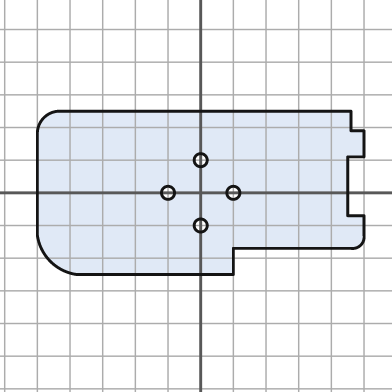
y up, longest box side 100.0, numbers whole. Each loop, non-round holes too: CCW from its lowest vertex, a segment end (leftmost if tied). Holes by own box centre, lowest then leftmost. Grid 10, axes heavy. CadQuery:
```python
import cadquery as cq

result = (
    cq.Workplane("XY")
    .moveTo(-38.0, -25.0)
    .lineTo(10.0, -25.0)
    .lineTo(10.0, -17.0)
    .lineTo(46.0, -17.0)
    .threePointArc((49.0, -16.0), (50.0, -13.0))
    .lineTo(50.0, -7.0)
    .lineTo(45.0, -7.0)
    .lineTo(45.0, 11.0)
    .lineTo(50.0, 11.0)
    .lineTo(50.0, 19.0)
    .lineTo(46.0, 19.0)
    .lineTo(46.0, 25.0)
    .lineTo(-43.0, 25.0)
    .threePointArc((-48.0, 23.0), (-50.0, 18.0))
    .lineTo(-50.0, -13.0)
    .threePointArc((-46.0, -21.0), (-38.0, -25.0))
    .close()
    .moveTo(0.0, -10.0)
    .circle(2.0)
    .moveTo(-10.0, 0.0)
    .circle(2.0)
    .moveTo(10.0, 0.0)
    .circle(2.0)
    .moveTo(0.0, 10.0)
    .circle(2.0)
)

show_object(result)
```